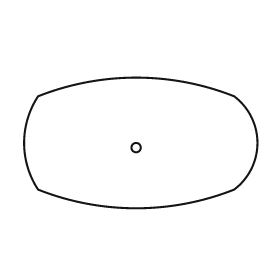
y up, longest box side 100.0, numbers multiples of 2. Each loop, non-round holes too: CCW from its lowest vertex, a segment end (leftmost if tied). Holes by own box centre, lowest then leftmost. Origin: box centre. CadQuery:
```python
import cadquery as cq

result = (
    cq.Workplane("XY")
    .moveTo(-44.0, -20.0)
    .threePointArc((-2.0, -28.0), (40.0, -20.0))
    .threePointArc((50.0, 0.0), (40.0, 20.0))
    .threePointArc((-2.0, 28.0), (-44.0, 20.0))
    .threePointArc((-50.0, 0.0), (-44.0, -20.0))
    .close()
    .moveTo(-2.0, -2.0)
    .circle(2.0)
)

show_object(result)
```